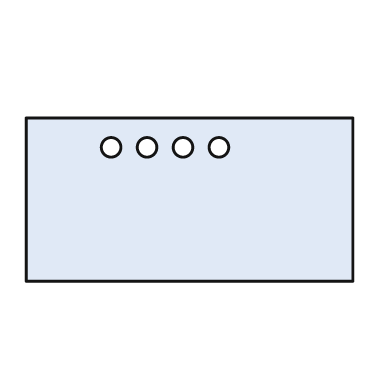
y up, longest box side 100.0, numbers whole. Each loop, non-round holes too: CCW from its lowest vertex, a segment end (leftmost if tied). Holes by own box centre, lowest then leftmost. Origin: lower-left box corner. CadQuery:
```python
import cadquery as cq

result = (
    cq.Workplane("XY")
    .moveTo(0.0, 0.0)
    .lineTo(100.0, 0.0)
    .lineTo(100.0, 50.0)
    .lineTo(0.0, 50.0)
    .close()
    .moveTo(26.0, 41.0)
    .circle(3.0)
    .moveTo(37.0, 41.0)
    .circle(3.0)
    .moveTo(48.0, 41.0)
    .circle(3.0)
    .moveTo(59.0, 41.0)
    .circle(3.0)
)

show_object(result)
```